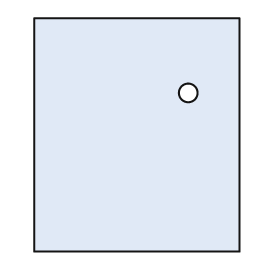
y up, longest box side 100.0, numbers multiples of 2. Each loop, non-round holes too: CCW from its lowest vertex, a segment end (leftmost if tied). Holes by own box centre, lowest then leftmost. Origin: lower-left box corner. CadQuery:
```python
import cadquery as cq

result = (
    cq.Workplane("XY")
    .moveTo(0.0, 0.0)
    .lineTo(88.0, 0.0)
    .lineTo(88.0, 100.0)
    .lineTo(0.0, 100.0)
    .close()
    .moveTo(66.0, 68.0)
    .circle(4.0)
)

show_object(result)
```